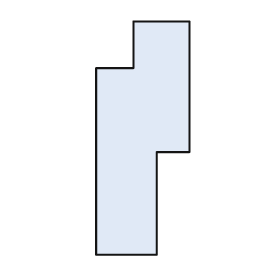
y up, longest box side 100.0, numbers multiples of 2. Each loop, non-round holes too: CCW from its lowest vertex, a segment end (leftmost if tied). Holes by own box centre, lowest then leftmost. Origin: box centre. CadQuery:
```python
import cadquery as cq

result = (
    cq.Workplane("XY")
    .moveTo(-20.0, -50.0)
    .lineTo(6.0, -50.0)
    .lineTo(6.0, -6.0)
    .lineTo(20.0, -6.0)
    .lineTo(20.0, 50.0)
    .lineTo(-4.0, 50.0)
    .lineTo(-4.0, 30.0)
    .lineTo(-20.0, 30.0)
    .close()
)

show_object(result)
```